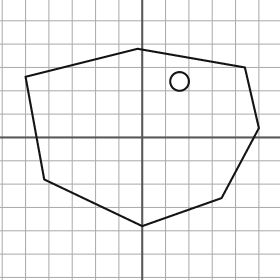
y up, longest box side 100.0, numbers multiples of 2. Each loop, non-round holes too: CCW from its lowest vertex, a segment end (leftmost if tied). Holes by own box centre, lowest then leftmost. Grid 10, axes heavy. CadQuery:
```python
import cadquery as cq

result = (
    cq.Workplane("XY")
    .moveTo(0.0, -38.0)
    .lineTo(34.0, -26.0)
    .lineTo(50.0, 4.0)
    .lineTo(44.0, 30.0)
    .lineTo(-2.0, 38.0)
    .lineTo(-50.0, 26.0)
    .lineTo(-42.0, -18.0)
    .close()
    .moveTo(16.0, 24.0)
    .circle(4.0)
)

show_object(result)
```